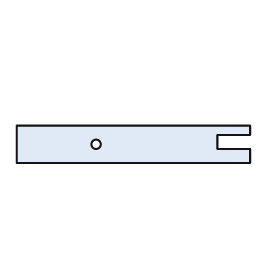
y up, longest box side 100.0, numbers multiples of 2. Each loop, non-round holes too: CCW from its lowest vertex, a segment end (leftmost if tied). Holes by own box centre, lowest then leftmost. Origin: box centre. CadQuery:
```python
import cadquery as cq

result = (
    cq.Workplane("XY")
    .moveTo(-50.0, -8.0)
    .lineTo(50.0, -8.0)
    .lineTo(50.0, -2.0)
    .lineTo(36.0, -2.0)
    .lineTo(36.0, 4.0)
    .lineTo(50.0, 4.0)
    .lineTo(50.0, 8.0)
    .lineTo(-50.0, 8.0)
    .close()
    .moveTo(-16.0, 0.0)
    .circle(2.0)
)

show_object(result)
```